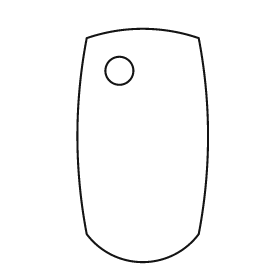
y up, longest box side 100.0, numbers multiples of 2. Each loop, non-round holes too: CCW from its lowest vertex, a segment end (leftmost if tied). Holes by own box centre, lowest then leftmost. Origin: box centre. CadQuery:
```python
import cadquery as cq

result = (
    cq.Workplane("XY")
    .moveTo(-24.0, -38.0)
    .threePointArc((0.0, -50.0), (24.0, -38.0))
    .threePointArc((28.0, 4.0), (24.0, 46.0))
    .threePointArc((0.0, 50.0), (-24.0, 46.0))
    .threePointArc((-28.0, 4.0), (-24.0, -38.0))
    .close()
    .moveTo(-10.0, 32.0)
    .circle(6.0)
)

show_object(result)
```